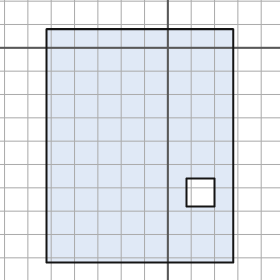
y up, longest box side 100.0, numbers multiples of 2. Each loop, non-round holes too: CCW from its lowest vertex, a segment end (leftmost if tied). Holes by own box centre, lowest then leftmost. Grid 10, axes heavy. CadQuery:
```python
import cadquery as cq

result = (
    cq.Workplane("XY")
    .moveTo(-52.0, -92.0)
    .lineTo(28.0, -92.0)
    .lineTo(28.0, 8.0)
    .lineTo(-52.0, 8.0)
    .close()
    .moveTo(8.0, -68.0)
    .lineTo(20.0, -68.0)
    .lineTo(20.0, -56.0)
    .lineTo(8.0, -56.0)
    .close()
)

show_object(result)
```